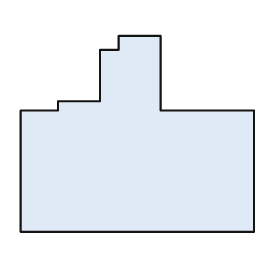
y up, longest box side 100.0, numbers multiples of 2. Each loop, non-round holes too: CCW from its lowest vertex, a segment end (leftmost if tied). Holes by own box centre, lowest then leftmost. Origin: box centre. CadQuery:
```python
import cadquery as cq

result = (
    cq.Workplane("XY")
    .moveTo(-50.0, -42.0)
    .lineTo(50.0, -42.0)
    .lineTo(50.0, 10.0)
    .lineTo(10.0, 10.0)
    .lineTo(10.0, 42.0)
    .lineTo(-8.0, 42.0)
    .lineTo(-8.0, 36.0)
    .lineTo(-16.0, 36.0)
    .lineTo(-16.0, 14.0)
    .lineTo(-34.0, 14.0)
    .lineTo(-34.0, 10.0)
    .lineTo(-50.0, 10.0)
    .close()
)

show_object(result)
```